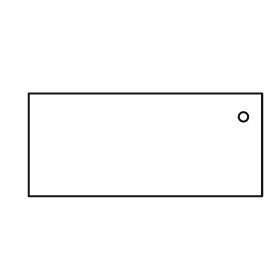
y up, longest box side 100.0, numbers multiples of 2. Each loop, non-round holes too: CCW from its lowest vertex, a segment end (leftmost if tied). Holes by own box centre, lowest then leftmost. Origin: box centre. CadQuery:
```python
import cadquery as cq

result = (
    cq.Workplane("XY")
    .moveTo(-50.0, -22.0)
    .lineTo(50.0, -22.0)
    .lineTo(50.0, 22.0)
    .lineTo(-50.0, 22.0)
    .close()
    .moveTo(42.0, 12.0)
    .circle(2.0)
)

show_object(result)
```